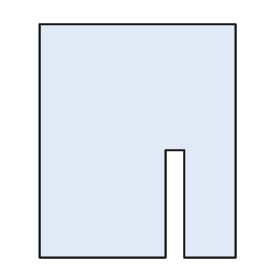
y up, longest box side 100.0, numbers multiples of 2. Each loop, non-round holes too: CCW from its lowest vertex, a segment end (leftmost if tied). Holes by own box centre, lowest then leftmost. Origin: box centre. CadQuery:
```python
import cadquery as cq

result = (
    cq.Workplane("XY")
    .moveTo(-42.0, -50.0)
    .lineTo(12.0, -50.0)
    .lineTo(12.0, -4.0)
    .lineTo(20.0, -4.0)
    .lineTo(20.0, -50.0)
    .lineTo(42.0, -50.0)
    .lineTo(42.0, 50.0)
    .lineTo(-42.0, 50.0)
    .close()
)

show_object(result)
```